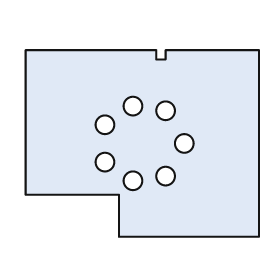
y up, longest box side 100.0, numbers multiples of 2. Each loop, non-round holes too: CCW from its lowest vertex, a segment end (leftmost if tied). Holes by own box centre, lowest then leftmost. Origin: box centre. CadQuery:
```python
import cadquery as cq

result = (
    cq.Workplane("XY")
    .moveTo(-10.0, -40.0)
    .lineTo(50.0, -40.0)
    .lineTo(50.0, 40.0)
    .lineTo(10.0, 40.0)
    .lineTo(10.0, 36.0)
    .lineTo(6.0, 36.0)
    .lineTo(6.0, 40.0)
    .lineTo(-50.0, 40.0)
    .lineTo(-50.0, -22.0)
    .lineTo(-10.0, -22.0)
    .close()
    .moveTo(-4.0, -16.0)
    .circle(4.0)
    .moveTo(10.0, -14.0)
    .circle(4.0)
    .moveTo(-16.0, -8.0)
    .circle(4.0)
    .moveTo(18.0, 0.0)
    .circle(4.0)
    .moveTo(-16.0, 8.0)
    .circle(4.0)
    .moveTo(10.0, 14.0)
    .circle(4.0)
    .moveTo(-4.0, 16.0)
    .circle(4.0)
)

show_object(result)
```